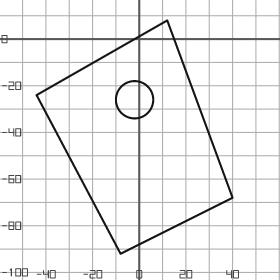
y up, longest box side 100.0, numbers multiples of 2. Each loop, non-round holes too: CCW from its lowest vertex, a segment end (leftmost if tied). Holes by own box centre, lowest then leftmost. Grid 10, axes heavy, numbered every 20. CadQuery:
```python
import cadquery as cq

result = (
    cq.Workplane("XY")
    .moveTo(-8.0, -92.0)
    .lineTo(40.0, -68.0)
    .lineTo(12.0, 8.0)
    .lineTo(-44.0, -24.0)
    .close()
    .moveTo(-2.0, -26.0)
    .circle(8.0)
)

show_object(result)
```